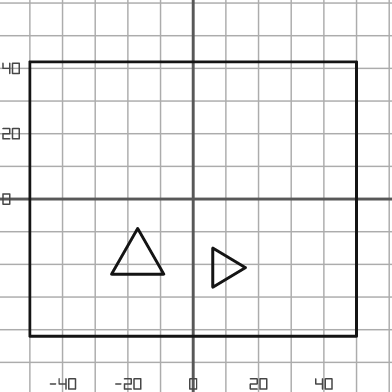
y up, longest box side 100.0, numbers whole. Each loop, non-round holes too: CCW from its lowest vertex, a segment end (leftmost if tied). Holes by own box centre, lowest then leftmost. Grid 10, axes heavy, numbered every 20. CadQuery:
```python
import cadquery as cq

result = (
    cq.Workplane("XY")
    .moveTo(-50.0, -42.0)
    .lineTo(50.0, -42.0)
    .lineTo(50.0, 42.0)
    .lineTo(-50.0, 42.0)
    .close()
    .moveTo(6.0, -27.0)
    .lineTo(16.0, -21.0)
    .lineTo(6.0, -15.0)
    .close()
    .moveTo(-25.0, -23.0)
    .lineTo(-9.0, -23.0)
    .lineTo(-17.0, -9.0)
    .close()
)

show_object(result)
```